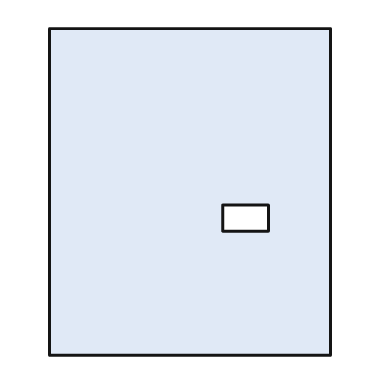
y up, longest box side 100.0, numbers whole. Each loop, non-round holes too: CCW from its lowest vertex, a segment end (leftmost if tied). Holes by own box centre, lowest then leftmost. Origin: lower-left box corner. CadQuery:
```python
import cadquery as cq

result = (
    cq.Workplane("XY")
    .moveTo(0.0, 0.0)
    .lineTo(86.0, 0.0)
    .lineTo(86.0, 100.0)
    .lineTo(0.0, 100.0)
    .close()
    .moveTo(53.0, 38.0)
    .lineTo(67.0, 38.0)
    .lineTo(67.0, 46.0)
    .lineTo(53.0, 46.0)
    .close()
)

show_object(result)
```